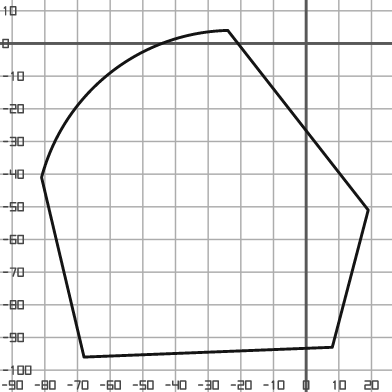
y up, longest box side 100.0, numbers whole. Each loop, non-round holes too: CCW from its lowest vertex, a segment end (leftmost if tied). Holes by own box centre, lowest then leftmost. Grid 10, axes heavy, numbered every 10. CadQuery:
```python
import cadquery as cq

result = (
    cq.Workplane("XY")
    .moveTo(-68.0, -96.0)
    .lineTo(8.0, -93.0)
    .lineTo(19.0, -51.0)
    .lineTo(-24.0, 4.0)
    .threePointArc((-60.0, -9.0), (-81.0, -41.0))
    .close()
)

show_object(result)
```